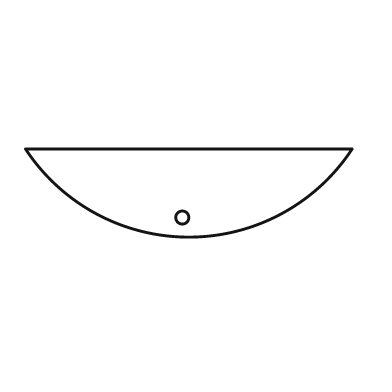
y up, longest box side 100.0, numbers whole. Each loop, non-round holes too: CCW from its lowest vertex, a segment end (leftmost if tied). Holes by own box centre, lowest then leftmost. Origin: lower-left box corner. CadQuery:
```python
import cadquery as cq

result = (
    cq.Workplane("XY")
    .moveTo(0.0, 27.0)
    .threePointArc((50.0, 0.0), (100.0, 27.0))
    .close()
    .moveTo(48.0, 6.0)
    .circle(2.0)
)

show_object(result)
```